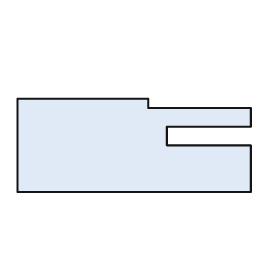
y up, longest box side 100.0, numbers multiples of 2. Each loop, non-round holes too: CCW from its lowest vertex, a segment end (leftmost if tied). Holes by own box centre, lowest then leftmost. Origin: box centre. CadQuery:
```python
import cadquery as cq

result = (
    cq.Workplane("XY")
    .moveTo(-50.0, -20.0)
    .lineTo(50.0, -20.0)
    .lineTo(50.0, 0.0)
    .lineTo(14.0, 0.0)
    .lineTo(14.0, 8.0)
    .lineTo(50.0, 8.0)
    .lineTo(50.0, 16.0)
    .lineTo(6.0, 16.0)
    .lineTo(6.0, 20.0)
    .lineTo(-50.0, 20.0)
    .close()
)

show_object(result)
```